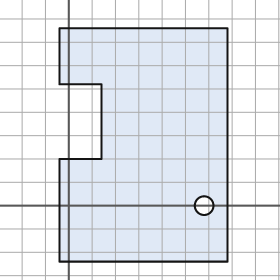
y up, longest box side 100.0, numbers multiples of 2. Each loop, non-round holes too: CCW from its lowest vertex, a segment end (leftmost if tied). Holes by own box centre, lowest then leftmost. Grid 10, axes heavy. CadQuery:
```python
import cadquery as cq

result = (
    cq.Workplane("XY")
    .moveTo(-4.0, -24.0)
    .lineTo(68.0, -24.0)
    .lineTo(68.0, 76.0)
    .lineTo(-4.0, 76.0)
    .lineTo(-4.0, 52.0)
    .lineTo(14.0, 52.0)
    .lineTo(14.0, 20.0)
    .lineTo(-4.0, 20.0)
    .close()
    .moveTo(58.0, 0.0)
    .circle(4.0)
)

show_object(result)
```